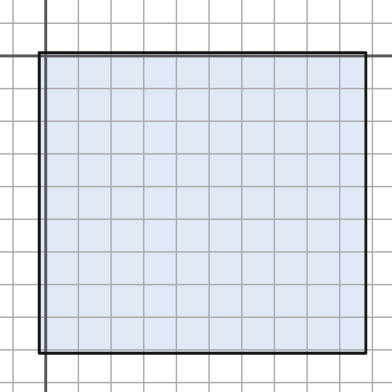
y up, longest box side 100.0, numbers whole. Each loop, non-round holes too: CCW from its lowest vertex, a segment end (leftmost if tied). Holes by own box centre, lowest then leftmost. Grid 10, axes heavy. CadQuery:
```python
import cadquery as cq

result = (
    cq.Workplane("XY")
    .moveTo(-2.0, -91.0)
    .lineTo(98.0, -91.0)
    .lineTo(98.0, 1.0)
    .lineTo(-2.0, 1.0)
    .close()
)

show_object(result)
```